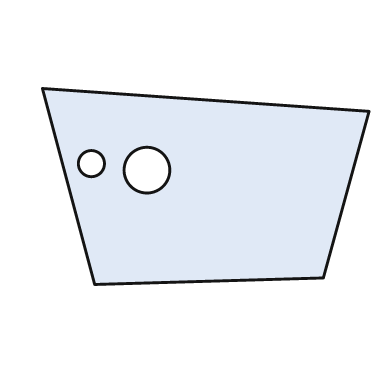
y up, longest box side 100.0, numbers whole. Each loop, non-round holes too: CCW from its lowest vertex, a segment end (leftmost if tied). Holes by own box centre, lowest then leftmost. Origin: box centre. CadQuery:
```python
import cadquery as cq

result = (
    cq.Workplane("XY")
    .moveTo(-34.0, -30.0)
    .lineTo(36.0, -28.0)
    .lineTo(50.0, 23.0)
    .lineTo(-50.0, 30.0)
    .close()
    .moveTo(-18.0, 5.0)
    .circle(7.0)
    .moveTo(-35.0, 7.0)
    .circle(4.0)
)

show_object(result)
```